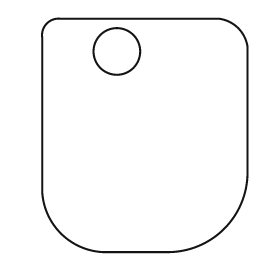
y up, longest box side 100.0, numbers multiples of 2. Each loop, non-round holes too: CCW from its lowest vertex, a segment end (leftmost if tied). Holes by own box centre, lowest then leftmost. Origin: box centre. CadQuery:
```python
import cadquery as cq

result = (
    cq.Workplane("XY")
    .moveTo(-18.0, -50.0)
    .lineTo(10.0, -50.0)
    .threePointArc((34.0, -40.0), (44.0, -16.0))
    .lineTo(44.0, 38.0)
    .threePointArc((40.0, 46.0), (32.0, 50.0))
    .lineTo(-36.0, 50.0)
    .threePointArc((-42.0, 48.0), (-44.0, 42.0))
    .lineTo(-44.0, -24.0)
    .threePointArc((-36.0, -42.0), (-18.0, -50.0))
    .close()
    .moveTo(-12.0, 36.0)
    .circle(10.0)
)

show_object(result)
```